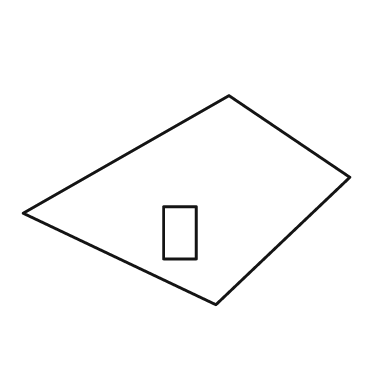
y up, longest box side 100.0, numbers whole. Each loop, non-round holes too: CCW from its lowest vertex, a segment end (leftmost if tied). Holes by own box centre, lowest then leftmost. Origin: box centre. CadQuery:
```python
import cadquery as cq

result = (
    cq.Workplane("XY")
    .moveTo(9.0, -32.0)
    .lineTo(50.0, 7.0)
    .lineTo(13.0, 32.0)
    .lineTo(-50.0, -4.0)
    .close()
    .moveTo(-7.0, -18.0)
    .lineTo(3.0, -18.0)
    .lineTo(3.0, -2.0)
    .lineTo(-7.0, -2.0)
    .close()
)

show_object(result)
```